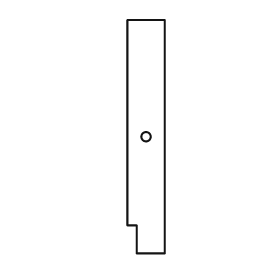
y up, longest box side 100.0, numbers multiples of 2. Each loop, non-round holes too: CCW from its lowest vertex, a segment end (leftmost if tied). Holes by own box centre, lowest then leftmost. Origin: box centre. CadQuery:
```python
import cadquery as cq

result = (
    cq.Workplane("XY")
    .moveTo(-4.0, -50.0)
    .lineTo(8.0, -50.0)
    .lineTo(8.0, 50.0)
    .lineTo(-8.0, 50.0)
    .lineTo(-8.0, -38.0)
    .lineTo(-4.0, -38.0)
    .close()
    .moveTo(0.0, 0.0)
    .circle(2.0)
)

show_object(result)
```